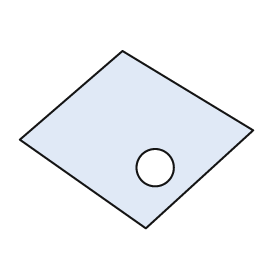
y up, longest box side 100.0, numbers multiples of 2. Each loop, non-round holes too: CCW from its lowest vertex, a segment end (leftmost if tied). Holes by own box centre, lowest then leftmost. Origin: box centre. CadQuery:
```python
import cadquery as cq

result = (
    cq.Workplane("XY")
    .moveTo(4.0, -38.0)
    .lineTo(50.0, 4.0)
    .lineTo(-6.0, 38.0)
    .lineTo(-50.0, 0.0)
    .close()
    .moveTo(8.0, -12.0)
    .circle(8.0)
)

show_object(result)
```